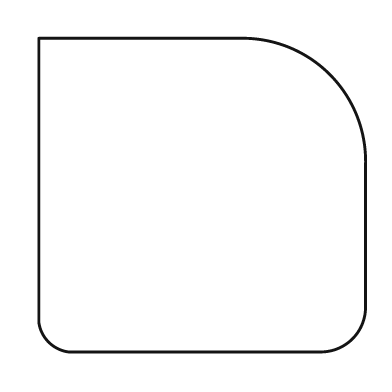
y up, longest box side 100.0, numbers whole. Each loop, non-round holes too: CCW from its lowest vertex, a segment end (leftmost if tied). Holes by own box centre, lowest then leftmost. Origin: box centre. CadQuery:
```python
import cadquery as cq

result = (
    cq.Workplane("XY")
    .moveTo(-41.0, -48.0)
    .lineTo(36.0, -48.0)
    .threePointArc((46.0, -44.0), (50.0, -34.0))
    .lineTo(50.0, 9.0)
    .threePointArc((39.0, 37.0), (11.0, 48.0))
    .lineTo(-50.0, 48.0)
    .lineTo(-50.0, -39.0)
    .threePointArc((-47.0, -45.0), (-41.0, -48.0))
    .close()
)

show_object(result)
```